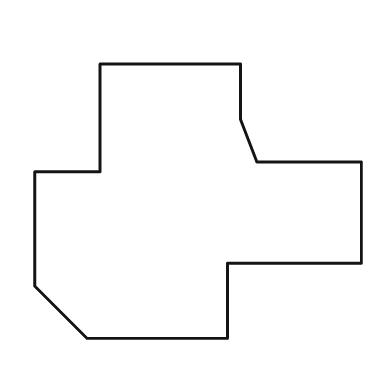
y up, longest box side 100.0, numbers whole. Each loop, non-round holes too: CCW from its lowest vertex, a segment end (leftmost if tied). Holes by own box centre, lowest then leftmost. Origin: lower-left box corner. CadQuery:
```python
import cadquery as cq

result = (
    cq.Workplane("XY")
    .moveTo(16.0, 0.0)
    .lineTo(59.0, 0.0)
    .lineTo(59.0, 23.0)
    .lineTo(100.0, 23.0)
    .lineTo(100.0, 54.0)
    .lineTo(68.0, 54.0)
    .lineTo(63.0, 67.0)
    .lineTo(63.0, 84.0)
    .lineTo(20.0, 84.0)
    .lineTo(20.0, 51.0)
    .lineTo(0.0, 51.0)
    .lineTo(0.0, 16.0)
    .close()
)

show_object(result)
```